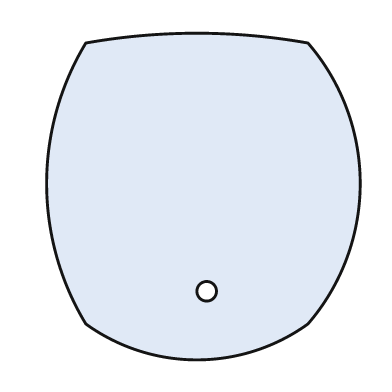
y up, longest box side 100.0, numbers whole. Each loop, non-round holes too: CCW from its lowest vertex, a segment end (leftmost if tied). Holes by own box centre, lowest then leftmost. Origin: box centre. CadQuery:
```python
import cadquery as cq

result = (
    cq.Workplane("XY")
    .moveTo(-36.0, -39.0)
    .threePointArc((-2.0, -50.0), (32.0, -39.0))
    .threePointArc((48.0, 4.0), (32.0, 47.0))
    .threePointArc((-2.0, 50.0), (-36.0, 47.0))
    .threePointArc((-48.0, 4.0), (-36.0, -39.0))
    .close()
    .moveTo(1.0, -29.0)
    .circle(3.0)
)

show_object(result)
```